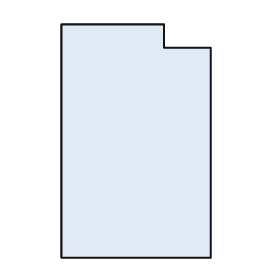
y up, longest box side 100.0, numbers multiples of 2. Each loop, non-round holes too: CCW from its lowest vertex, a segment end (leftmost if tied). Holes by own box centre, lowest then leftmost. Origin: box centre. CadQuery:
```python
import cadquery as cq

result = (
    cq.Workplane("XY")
    .moveTo(-32.0, -50.0)
    .lineTo(32.0, -50.0)
    .lineTo(32.0, 40.0)
    .lineTo(12.0, 40.0)
    .lineTo(12.0, 50.0)
    .lineTo(-32.0, 50.0)
    .close()
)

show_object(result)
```